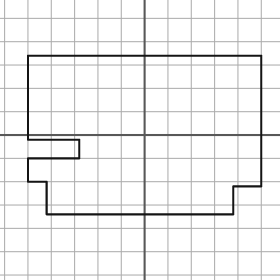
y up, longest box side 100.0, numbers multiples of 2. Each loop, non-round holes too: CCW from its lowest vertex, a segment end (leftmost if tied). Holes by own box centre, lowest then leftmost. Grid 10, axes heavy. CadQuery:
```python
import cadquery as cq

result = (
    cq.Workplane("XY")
    .moveTo(-42.0, -34.0)
    .lineTo(38.0, -34.0)
    .lineTo(38.0, -22.0)
    .lineTo(50.0, -22.0)
    .lineTo(50.0, 34.0)
    .lineTo(-50.0, 34.0)
    .lineTo(-50.0, -2.0)
    .lineTo(-28.0, -2.0)
    .lineTo(-28.0, -10.0)
    .lineTo(-50.0, -10.0)
    .lineTo(-50.0, -20.0)
    .lineTo(-42.0, -20.0)
    .close()
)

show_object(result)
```